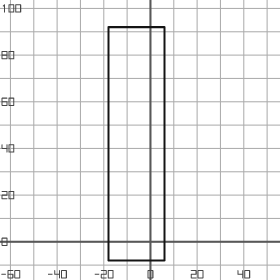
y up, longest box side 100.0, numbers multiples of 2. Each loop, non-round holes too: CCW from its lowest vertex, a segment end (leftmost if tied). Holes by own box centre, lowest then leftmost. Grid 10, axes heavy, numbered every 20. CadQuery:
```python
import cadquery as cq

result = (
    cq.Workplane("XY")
    .moveTo(-18.0, -8.0)
    .lineTo(6.0, -8.0)
    .lineTo(6.0, 92.0)
    .lineTo(-18.0, 92.0)
    .close()
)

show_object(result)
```